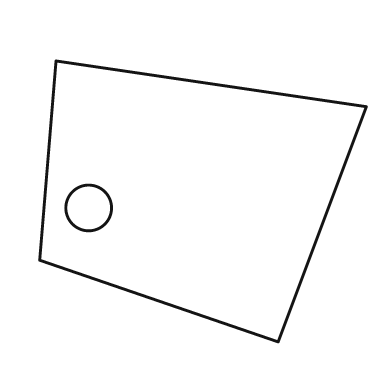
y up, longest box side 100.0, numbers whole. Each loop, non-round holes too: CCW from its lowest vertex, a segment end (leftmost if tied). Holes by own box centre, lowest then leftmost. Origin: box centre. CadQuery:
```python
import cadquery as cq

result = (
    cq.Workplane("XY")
    .moveTo(23.0, -43.0)
    .lineTo(50.0, 29.0)
    .lineTo(-45.0, 43.0)
    .lineTo(-50.0, -18.0)
    .close()
    .moveTo(-35.0, -2.0)
    .circle(7.0)
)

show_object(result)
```